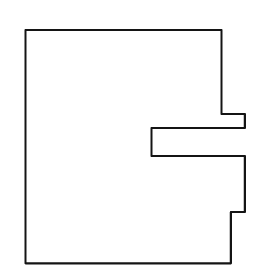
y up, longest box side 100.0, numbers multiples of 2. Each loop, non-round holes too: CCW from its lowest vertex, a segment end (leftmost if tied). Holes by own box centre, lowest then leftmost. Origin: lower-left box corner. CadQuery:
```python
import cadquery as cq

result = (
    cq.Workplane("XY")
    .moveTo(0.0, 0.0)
    .lineTo(88.0, 0.0)
    .lineTo(88.0, 22.0)
    .lineTo(94.0, 22.0)
    .lineTo(94.0, 46.0)
    .lineTo(54.0, 46.0)
    .lineTo(54.0, 58.0)
    .lineTo(94.0, 58.0)
    .lineTo(94.0, 64.0)
    .lineTo(84.0, 64.0)
    .lineTo(84.0, 100.0)
    .lineTo(0.0, 100.0)
    .close()
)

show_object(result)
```